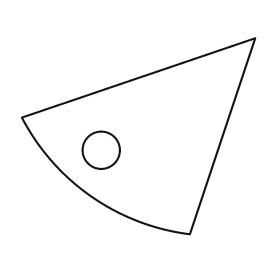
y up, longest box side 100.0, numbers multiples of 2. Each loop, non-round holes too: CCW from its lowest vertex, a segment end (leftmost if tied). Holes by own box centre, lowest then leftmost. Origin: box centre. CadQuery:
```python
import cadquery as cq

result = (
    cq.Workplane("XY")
    .moveTo(22.0, -42.0)
    .lineTo(50.0, 42.0)
    .lineTo(-50.0, 8.0)
    .threePointArc((-20.0, -26.0), (22.0, -42.0))
    .close()
    .moveTo(-16.0, -6.0)
    .circle(8.0)
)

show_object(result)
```